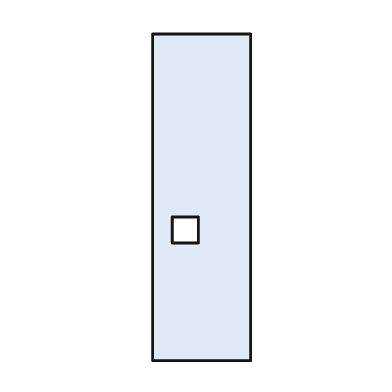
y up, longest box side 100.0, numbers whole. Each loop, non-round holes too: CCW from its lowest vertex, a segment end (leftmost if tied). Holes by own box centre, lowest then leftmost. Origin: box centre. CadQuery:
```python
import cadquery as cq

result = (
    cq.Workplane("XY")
    .moveTo(-15.0, -50.0)
    .lineTo(15.0, -50.0)
    .lineTo(15.0, 50.0)
    .lineTo(-15.0, 50.0)
    .close()
    .moveTo(-9.0, -14.0)
    .lineTo(-1.0, -14.0)
    .lineTo(-1.0, -6.0)
    .lineTo(-9.0, -6.0)
    .close()
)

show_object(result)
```